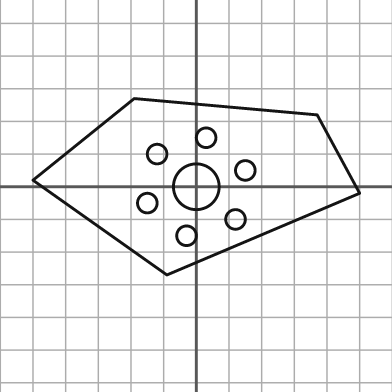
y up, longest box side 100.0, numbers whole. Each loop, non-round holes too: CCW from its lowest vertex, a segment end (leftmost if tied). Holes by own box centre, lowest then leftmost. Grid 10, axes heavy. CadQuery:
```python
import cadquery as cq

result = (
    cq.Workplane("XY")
    .moveTo(-9.0, -27.0)
    .lineTo(50.0, -2.0)
    .lineTo(37.0, 22.0)
    .lineTo(-19.0, 27.0)
    .lineTo(-50.0, 2.0)
    .close()
    .moveTo(-3.0, -15.0)
    .circle(3.0)
    .moveTo(12.0, -10.0)
    .circle(3.0)
    .moveTo(-15.0, -5.0)
    .circle(3.0)
    .moveTo(0.0, 0.0)
    .circle(7.0)
    .moveTo(15.0, 5.0)
    .circle(3.0)
    .moveTo(-12.0, 10.0)
    .circle(3.0)
    .moveTo(3.0, 15.0)
    .circle(3.0)
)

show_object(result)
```